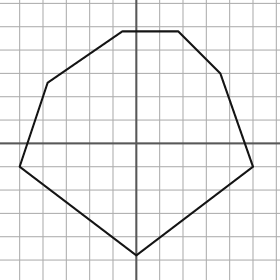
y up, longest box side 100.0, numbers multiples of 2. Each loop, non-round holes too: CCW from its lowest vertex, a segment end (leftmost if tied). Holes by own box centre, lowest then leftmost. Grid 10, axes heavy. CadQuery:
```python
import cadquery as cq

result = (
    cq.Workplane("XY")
    .moveTo(0.0, -48.0)
    .lineTo(50.0, -10.0)
    .lineTo(36.0, 30.0)
    .lineTo(18.0, 48.0)
    .lineTo(-6.0, 48.0)
    .lineTo(-38.0, 26.0)
    .lineTo(-50.0, -10.0)
    .close()
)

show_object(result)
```